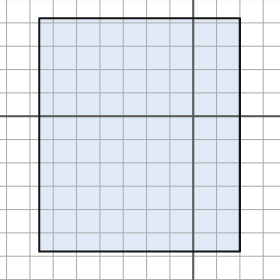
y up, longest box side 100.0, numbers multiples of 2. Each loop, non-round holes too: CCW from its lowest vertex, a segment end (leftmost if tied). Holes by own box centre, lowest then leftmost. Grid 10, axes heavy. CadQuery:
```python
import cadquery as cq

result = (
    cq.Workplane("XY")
    .moveTo(-66.0, -58.0)
    .lineTo(20.0, -58.0)
    .lineTo(20.0, 42.0)
    .lineTo(-66.0, 42.0)
    .close()
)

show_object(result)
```